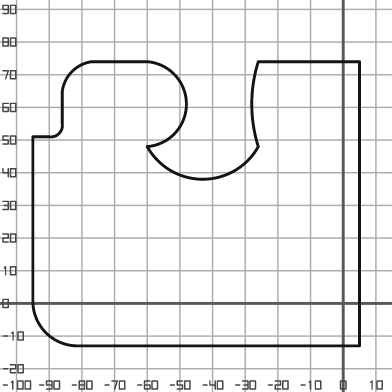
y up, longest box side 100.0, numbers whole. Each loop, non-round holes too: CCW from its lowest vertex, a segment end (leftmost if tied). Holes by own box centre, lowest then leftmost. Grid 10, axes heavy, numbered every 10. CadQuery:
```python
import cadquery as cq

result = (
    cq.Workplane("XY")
    .moveTo(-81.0, -13.0)
    .lineTo(5.0, -13.0)
    .lineTo(5.0, 74.0)
    .lineTo(-26.0, 74.0)
    .threePointArc((-28.0, 61.0), (-26.0, 48.0))
    .threePointArc((-43.0, 38.0), (-60.0, 48.0))
    .threePointArc((-48.0, 61.0), (-60.0, 74.0))
    .lineTo(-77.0, 74.0)
    .threePointArc((-83.0, 71.0), (-86.0, 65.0))
    .lineTo(-86.0, 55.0)
    .threePointArc((-87.0, 52.0), (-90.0, 51.0))
    .lineTo(-95.0, 51.0)
    .lineTo(-95.0, 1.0)
    .threePointArc((-91.0, -9.0), (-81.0, -13.0))
    .close()
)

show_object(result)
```